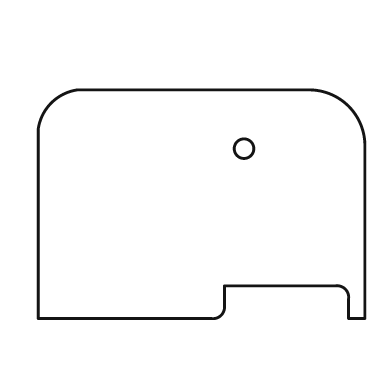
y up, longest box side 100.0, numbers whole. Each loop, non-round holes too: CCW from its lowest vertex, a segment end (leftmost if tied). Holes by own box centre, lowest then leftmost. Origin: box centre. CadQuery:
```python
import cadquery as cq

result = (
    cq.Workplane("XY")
    .moveTo(-50.0, -35.0)
    .lineTo(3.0, -35.0)
    .threePointArc((6.0, -34.0), (7.0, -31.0))
    .lineTo(7.0, -25.0)
    .lineTo(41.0, -25.0)
    .threePointArc((44.0, -26.0), (45.0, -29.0))
    .lineTo(45.0, -35.0)
    .lineTo(50.0, -35.0)
    .lineTo(50.0, 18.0)
    .threePointArc((45.0, 30.0), (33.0, 35.0))
    .lineTo(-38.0, 35.0)
    .threePointArc((-46.0, 31.0), (-50.0, 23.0))
    .close()
    .moveTo(13.0, 17.0)
    .circle(3.0)
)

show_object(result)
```